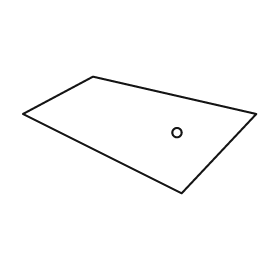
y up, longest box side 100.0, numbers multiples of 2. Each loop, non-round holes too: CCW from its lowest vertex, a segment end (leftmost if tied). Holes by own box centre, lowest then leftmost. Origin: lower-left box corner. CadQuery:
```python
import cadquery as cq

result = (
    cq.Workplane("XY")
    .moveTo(68.0, 0.0)
    .lineTo(100.0, 34.0)
    .lineTo(30.0, 50.0)
    .lineTo(0.0, 34.0)
    .close()
    .moveTo(66.0, 26.0)
    .circle(2.0)
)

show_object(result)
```